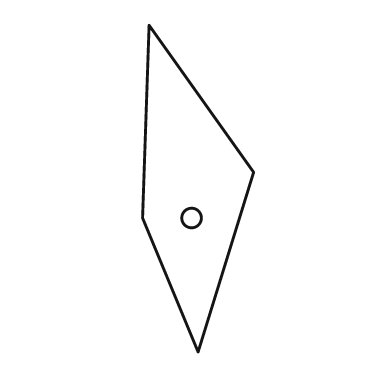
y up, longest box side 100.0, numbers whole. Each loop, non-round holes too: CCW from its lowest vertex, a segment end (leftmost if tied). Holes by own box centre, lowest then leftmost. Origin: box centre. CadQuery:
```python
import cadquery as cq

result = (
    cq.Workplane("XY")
    .moveTo(0.0, -50.0)
    .lineTo(17.0, 5.0)
    .lineTo(-15.0, 50.0)
    .lineTo(-17.0, -9.0)
    .close()
    .moveTo(-2.0, -9.0)
    .circle(3.0)
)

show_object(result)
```